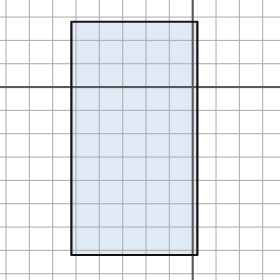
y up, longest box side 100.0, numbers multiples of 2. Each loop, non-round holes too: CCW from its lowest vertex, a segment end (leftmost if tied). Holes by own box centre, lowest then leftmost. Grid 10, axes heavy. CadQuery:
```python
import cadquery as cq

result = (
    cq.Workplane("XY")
    .moveTo(-52.0, -72.0)
    .lineTo(2.0, -72.0)
    .lineTo(2.0, 28.0)
    .lineTo(-52.0, 28.0)
    .close()
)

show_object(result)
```